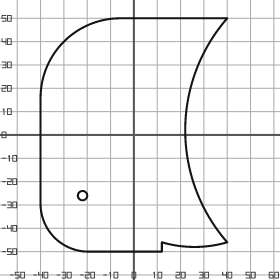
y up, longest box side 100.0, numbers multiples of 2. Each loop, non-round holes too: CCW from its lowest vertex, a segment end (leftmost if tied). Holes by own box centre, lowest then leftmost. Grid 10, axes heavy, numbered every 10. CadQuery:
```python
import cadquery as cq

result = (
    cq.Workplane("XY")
    .moveTo(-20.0, -50.0)
    .lineTo(12.0, -50.0)
    .lineTo(12.0, -46.0)
    .threePointArc((26.0, -48.0), (40.0, -46.0))
    .threePointArc((22.0, 2.0), (40.0, 50.0))
    .lineTo(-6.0, 50.0)
    .threePointArc((-30.0, 40.0), (-40.0, 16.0))
    .lineTo(-40.0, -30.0)
    .threePointArc((-34.0, -44.0), (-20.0, -50.0))
    .close()
    .moveTo(-22.0, -26.0)
    .circle(2.0)
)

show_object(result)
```